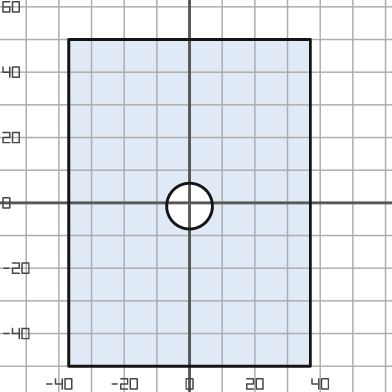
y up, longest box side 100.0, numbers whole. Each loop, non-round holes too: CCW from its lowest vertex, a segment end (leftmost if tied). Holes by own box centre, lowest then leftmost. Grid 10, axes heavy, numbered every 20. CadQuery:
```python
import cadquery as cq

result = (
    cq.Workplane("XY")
    .moveTo(-37.0, -50.0)
    .lineTo(37.0, -50.0)
    .lineTo(37.0, 50.0)
    .lineTo(-37.0, 50.0)
    .close()
    .moveTo(0.0, -1.0)
    .circle(7.0)
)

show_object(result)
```